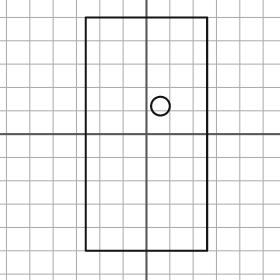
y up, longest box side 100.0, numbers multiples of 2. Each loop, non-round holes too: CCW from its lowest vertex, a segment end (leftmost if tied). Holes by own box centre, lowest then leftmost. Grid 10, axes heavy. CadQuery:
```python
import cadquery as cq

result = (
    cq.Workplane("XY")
    .moveTo(-26.0, -50.0)
    .lineTo(26.0, -50.0)
    .lineTo(26.0, 50.0)
    .lineTo(-26.0, 50.0)
    .close()
    .moveTo(6.0, 12.0)
    .circle(4.0)
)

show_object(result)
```